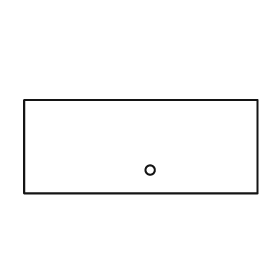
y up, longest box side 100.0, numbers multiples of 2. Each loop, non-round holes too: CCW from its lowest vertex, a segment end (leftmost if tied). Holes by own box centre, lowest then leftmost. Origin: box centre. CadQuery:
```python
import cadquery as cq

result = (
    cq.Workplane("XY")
    .moveTo(-50.0, -20.0)
    .lineTo(50.0, -20.0)
    .lineTo(50.0, 20.0)
    .lineTo(-50.0, 20.0)
    .close()
    .moveTo(4.0, -10.0)
    .circle(2.0)
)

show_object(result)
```